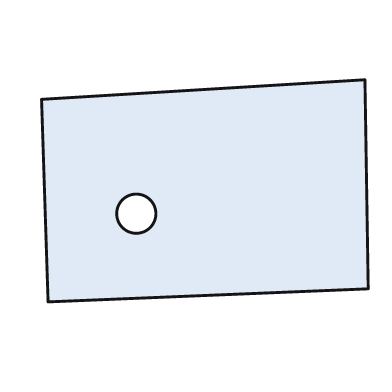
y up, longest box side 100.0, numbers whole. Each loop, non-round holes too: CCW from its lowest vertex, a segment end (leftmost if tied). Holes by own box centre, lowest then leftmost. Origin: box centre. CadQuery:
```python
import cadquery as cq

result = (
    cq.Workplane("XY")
    .moveTo(-48.0, -34.0)
    .lineTo(50.0, -30.0)
    .lineTo(49.0, 34.0)
    .lineTo(-50.0, 28.0)
    .close()
    .moveTo(-21.0, -7.0)
    .circle(6.0)
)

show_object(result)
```